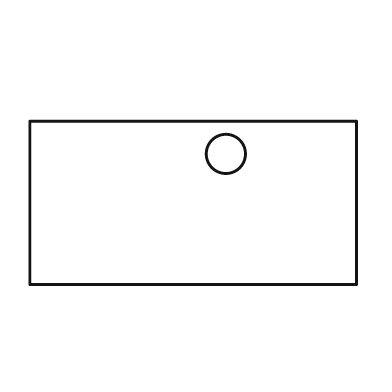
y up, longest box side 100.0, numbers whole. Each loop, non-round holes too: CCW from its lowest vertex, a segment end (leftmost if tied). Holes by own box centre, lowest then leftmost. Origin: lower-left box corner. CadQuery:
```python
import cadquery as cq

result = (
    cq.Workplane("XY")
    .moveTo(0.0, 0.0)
    .lineTo(100.0, 0.0)
    .lineTo(100.0, 50.0)
    .lineTo(0.0, 50.0)
    .close()
    .moveTo(60.0, 40.0)
    .circle(6.0)
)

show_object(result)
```